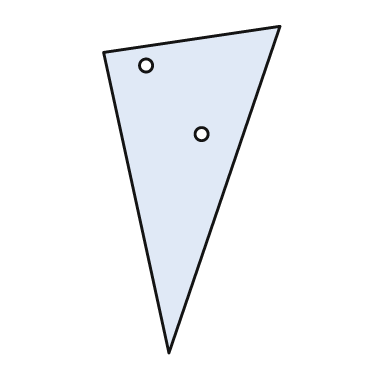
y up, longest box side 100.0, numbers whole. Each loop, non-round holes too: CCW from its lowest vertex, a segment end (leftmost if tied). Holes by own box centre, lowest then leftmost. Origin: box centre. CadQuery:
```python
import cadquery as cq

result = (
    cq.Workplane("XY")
    .moveTo(-7.0, -50.0)
    .lineTo(27.0, 50.0)
    .lineTo(-27.0, 42.0)
    .close()
    .moveTo(3.0, 17.0)
    .circle(2.0)
    .moveTo(-14.0, 38.0)
    .circle(2.0)
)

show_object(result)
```